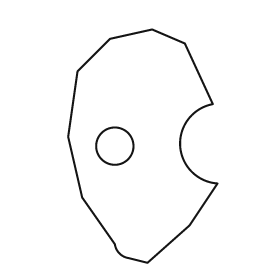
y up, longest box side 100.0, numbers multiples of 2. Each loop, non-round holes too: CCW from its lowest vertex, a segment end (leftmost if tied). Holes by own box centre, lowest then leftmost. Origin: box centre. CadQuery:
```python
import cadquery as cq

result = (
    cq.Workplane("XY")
    .moveTo(2.0, -50.0)
    .lineTo(20.0, -34.0)
    .lineTo(32.0, -16.0)
    .threePointArc((16.0, 0.0), (30.0, 18.0))
    .lineTo(18.0, 44.0)
    .lineTo(4.0, 50.0)
    .lineTo(-14.0, 46.0)
    .lineTo(-28.0, 32.0)
    .lineTo(-32.0, 4.0)
    .lineTo(-26.0, -22.0)
    .lineTo(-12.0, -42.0)
    .threePointArc((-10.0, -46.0), (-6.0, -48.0))
    .close()
    .moveTo(-12.0, 0.0)
    .circle(8.0)
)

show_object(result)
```